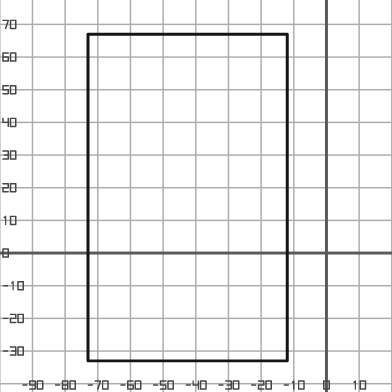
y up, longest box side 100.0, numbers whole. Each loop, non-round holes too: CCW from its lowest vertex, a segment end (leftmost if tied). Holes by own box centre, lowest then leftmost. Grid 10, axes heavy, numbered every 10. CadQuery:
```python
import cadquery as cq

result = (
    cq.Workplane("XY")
    .moveTo(-73.0, -33.0)
    .lineTo(-12.0, -33.0)
    .lineTo(-12.0, 67.0)
    .lineTo(-73.0, 67.0)
    .close()
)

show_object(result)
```